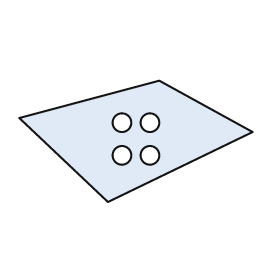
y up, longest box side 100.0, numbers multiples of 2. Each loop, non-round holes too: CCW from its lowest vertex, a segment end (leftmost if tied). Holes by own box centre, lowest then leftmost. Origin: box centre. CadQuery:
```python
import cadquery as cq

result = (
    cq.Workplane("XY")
    .moveTo(-12.0, -26.0)
    .lineTo(50.0, 4.0)
    .lineTo(10.0, 26.0)
    .lineTo(-50.0, 10.0)
    .close()
    .moveTo(-6.0, -6.0)
    .circle(4.0)
    .moveTo(6.0, -6.0)
    .circle(4.0)
    .moveTo(-6.0, 8.0)
    .circle(4.0)
    .moveTo(6.0, 8.0)
    .circle(4.0)
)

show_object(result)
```